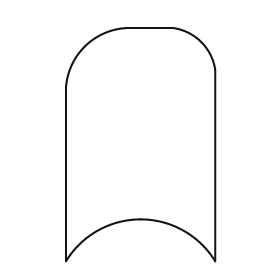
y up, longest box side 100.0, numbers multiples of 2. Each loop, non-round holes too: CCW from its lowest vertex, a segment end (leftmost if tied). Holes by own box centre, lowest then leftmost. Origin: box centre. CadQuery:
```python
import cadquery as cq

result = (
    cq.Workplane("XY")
    .moveTo(-32.0, -50.0)
    .threePointArc((0.0, -32.0), (32.0, -50.0))
    .lineTo(32.0, 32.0)
    .threePointArc((26.0, 44.0), (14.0, 50.0))
    .lineTo(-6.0, 50.0)
    .threePointArc((-24.0, 42.0), (-32.0, 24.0))
    .close()
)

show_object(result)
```